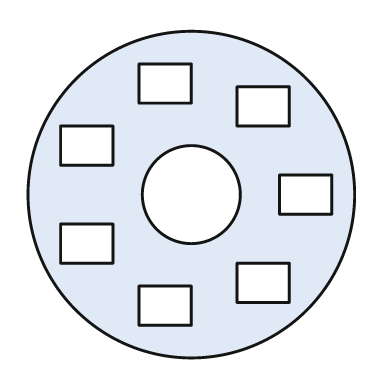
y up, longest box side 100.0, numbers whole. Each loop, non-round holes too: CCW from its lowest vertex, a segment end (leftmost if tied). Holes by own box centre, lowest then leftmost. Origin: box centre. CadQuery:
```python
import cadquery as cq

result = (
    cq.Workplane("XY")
    .moveTo(0.0, 0.0)
    .circle(50.0)
    .moveTo(-16.0, -40.0)
    .lineTo(0.0, -40.0)
    .lineTo(0.0, -28.0)
    .lineTo(-16.0, -28.0)
    .close()
    .moveTo(14.0, -33.0)
    .lineTo(30.0, -33.0)
    .lineTo(30.0, -21.0)
    .lineTo(14.0, -21.0)
    .close()
    .moveTo(-40.0, -21.0)
    .lineTo(-24.0, -21.0)
    .lineTo(-24.0, -9.0)
    .lineTo(-40.0, -9.0)
    .close()
    .moveTo(0.0, 0.0)
    .circle(15.0)
    .moveTo(27.0, -6.0)
    .lineTo(43.0, -6.0)
    .lineTo(43.0, 6.0)
    .lineTo(27.0, 6.0)
    .close()
    .moveTo(-40.0, 9.0)
    .lineTo(-24.0, 9.0)
    .lineTo(-24.0, 21.0)
    .lineTo(-40.0, 21.0)
    .close()
    .moveTo(14.0, 21.0)
    .lineTo(30.0, 21.0)
    .lineTo(30.0, 33.0)
    .lineTo(14.0, 33.0)
    .close()
    .moveTo(-16.0, 28.0)
    .lineTo(0.0, 28.0)
    .lineTo(0.0, 40.0)
    .lineTo(-16.0, 40.0)
    .close()
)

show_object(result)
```